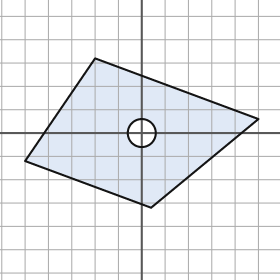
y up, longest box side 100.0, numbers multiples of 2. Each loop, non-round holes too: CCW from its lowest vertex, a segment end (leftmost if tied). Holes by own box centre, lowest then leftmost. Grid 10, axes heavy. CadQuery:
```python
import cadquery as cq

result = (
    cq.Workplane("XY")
    .moveTo(4.0, -32.0)
    .lineTo(50.0, 6.0)
    .lineTo(-20.0, 32.0)
    .lineTo(-50.0, -12.0)
    .close()
    .moveTo(0.0, 0.0)
    .circle(6.0)
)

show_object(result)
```